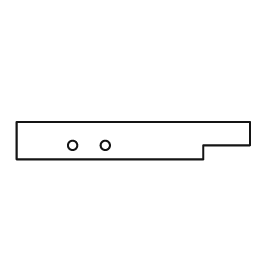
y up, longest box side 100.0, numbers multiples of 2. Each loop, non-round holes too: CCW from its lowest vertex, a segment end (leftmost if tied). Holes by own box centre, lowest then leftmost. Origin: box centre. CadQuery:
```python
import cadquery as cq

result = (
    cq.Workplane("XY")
    .moveTo(-50.0, -8.0)
    .lineTo(30.0, -8.0)
    .lineTo(30.0, -2.0)
    .lineTo(50.0, -2.0)
    .lineTo(50.0, 8.0)
    .lineTo(-50.0, 8.0)
    .close()
    .moveTo(-26.0, -2.0)
    .circle(2.0)
    .moveTo(-12.0, -2.0)
    .circle(2.0)
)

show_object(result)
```